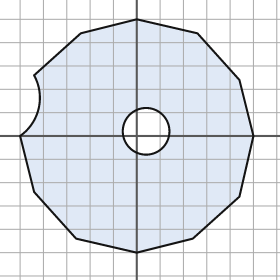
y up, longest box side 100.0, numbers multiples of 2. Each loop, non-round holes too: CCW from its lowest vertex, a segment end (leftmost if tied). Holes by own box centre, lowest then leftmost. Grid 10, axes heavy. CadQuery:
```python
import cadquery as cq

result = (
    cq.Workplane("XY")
    .moveTo(0.0, -50.0)
    .lineTo(24.0, -44.0)
    .lineTo(44.0, -26.0)
    .lineTo(50.0, 0.0)
    .lineTo(44.0, 24.0)
    .lineTo(26.0, 44.0)
    .lineTo(0.0, 50.0)
    .lineTo(-24.0, 44.0)
    .lineTo(-44.0, 26.0)
    .threePointArc((-42.0, 12.0), (-50.0, 0.0))
    .lineTo(-44.0, -24.0)
    .lineTo(-26.0, -44.0)
    .close()
    .moveTo(4.0, 2.0)
    .circle(10.0)
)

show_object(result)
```